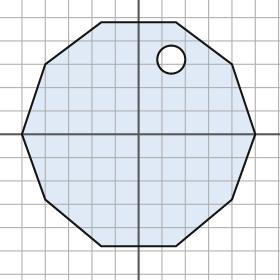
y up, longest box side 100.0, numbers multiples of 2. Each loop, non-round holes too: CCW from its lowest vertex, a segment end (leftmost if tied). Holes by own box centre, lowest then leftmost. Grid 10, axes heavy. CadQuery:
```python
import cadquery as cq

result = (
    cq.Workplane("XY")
    .moveTo(-16.0, -48.0)
    .lineTo(16.0, -48.0)
    .lineTo(40.0, -28.0)
    .lineTo(50.0, 0.0)
    .lineTo(40.0, 30.0)
    .lineTo(16.0, 48.0)
    .lineTo(-16.0, 48.0)
    .lineTo(-40.0, 30.0)
    .lineTo(-50.0, 0.0)
    .lineTo(-40.0, -28.0)
    .close()
    .moveTo(14.0, 32.0)
    .circle(6.0)
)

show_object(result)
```